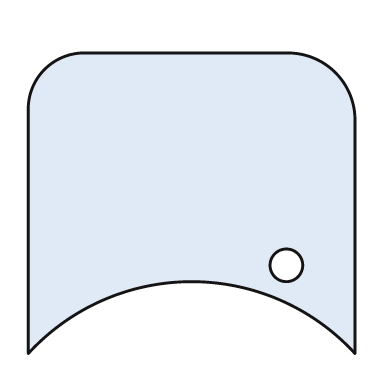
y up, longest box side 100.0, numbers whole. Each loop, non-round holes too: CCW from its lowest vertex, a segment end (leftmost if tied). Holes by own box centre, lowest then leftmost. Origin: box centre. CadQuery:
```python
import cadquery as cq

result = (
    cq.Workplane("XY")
    .moveTo(-50.0, -46.0)
    .threePointArc((0.0, -24.0), (50.0, -46.0))
    .lineTo(50.0, 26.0)
    .threePointArc((44.0, 40.0), (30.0, 46.0))
    .lineTo(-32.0, 46.0)
    .threePointArc((-45.0, 41.0), (-50.0, 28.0))
    .close()
    .moveTo(29.0, -19.0)
    .circle(5.0)
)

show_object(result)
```